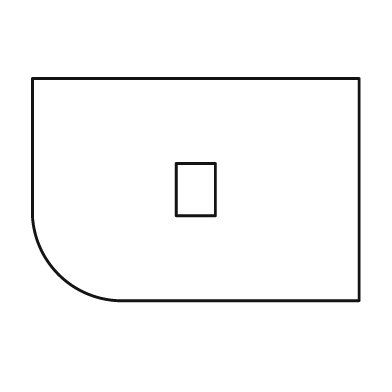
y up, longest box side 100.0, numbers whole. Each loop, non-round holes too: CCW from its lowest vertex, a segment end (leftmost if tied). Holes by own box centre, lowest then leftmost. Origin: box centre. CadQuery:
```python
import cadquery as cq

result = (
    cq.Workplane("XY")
    .moveTo(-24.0, -34.0)
    .lineTo(50.0, -34.0)
    .lineTo(50.0, 34.0)
    .lineTo(-50.0, 34.0)
    .lineTo(-50.0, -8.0)
    .threePointArc((-42.0, -26.0), (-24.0, -34.0))
    .close()
    .moveTo(-6.0, -8.0)
    .lineTo(6.0, -8.0)
    .lineTo(6.0, 8.0)
    .lineTo(-6.0, 8.0)
    .close()
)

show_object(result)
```